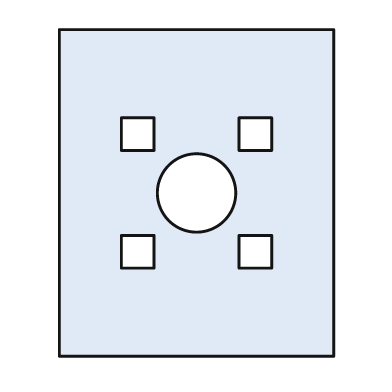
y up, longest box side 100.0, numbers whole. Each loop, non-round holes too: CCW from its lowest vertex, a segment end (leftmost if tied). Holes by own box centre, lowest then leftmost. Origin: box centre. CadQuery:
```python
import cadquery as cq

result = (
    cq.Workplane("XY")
    .moveTo(-42.0, -50.0)
    .lineTo(42.0, -50.0)
    .lineTo(42.0, 50.0)
    .lineTo(-42.0, 50.0)
    .close()
    .moveTo(-23.0, -23.0)
    .lineTo(-13.0, -23.0)
    .lineTo(-13.0, -13.0)
    .lineTo(-23.0, -13.0)
    .close()
    .moveTo(13.0, -23.0)
    .lineTo(23.0, -23.0)
    .lineTo(23.0, -13.0)
    .lineTo(13.0, -13.0)
    .close()
    .moveTo(0.0, 0.0)
    .circle(12.0)
    .moveTo(-23.0, 13.0)
    .lineTo(-13.0, 13.0)
    .lineTo(-13.0, 23.0)
    .lineTo(-23.0, 23.0)
    .close()
    .moveTo(13.0, 13.0)
    .lineTo(23.0, 13.0)
    .lineTo(23.0, 23.0)
    .lineTo(13.0, 23.0)
    .close()
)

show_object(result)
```